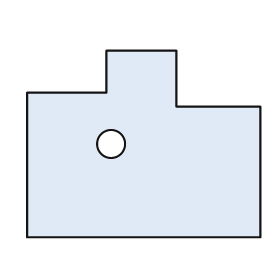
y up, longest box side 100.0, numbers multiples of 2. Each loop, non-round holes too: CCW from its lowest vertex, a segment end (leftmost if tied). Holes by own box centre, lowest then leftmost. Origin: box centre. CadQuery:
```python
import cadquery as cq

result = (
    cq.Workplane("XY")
    .moveTo(-50.0, -40.0)
    .lineTo(50.0, -40.0)
    .lineTo(50.0, 16.0)
    .lineTo(14.0, 16.0)
    .lineTo(14.0, 40.0)
    .lineTo(-16.0, 40.0)
    .lineTo(-16.0, 22.0)
    .lineTo(-50.0, 22.0)
    .close()
    .moveTo(-14.0, 0.0)
    .circle(6.0)
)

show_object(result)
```